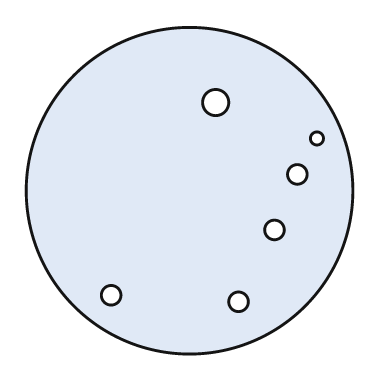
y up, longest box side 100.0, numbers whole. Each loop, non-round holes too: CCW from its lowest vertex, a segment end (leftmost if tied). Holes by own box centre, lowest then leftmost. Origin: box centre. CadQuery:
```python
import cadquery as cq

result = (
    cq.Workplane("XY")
    .moveTo(0.0, 0.0)
    .circle(50.0)
    .moveTo(15.0, -34.0)
    .circle(3.0)
    .moveTo(-24.0, -32.0)
    .circle(3.0)
    .moveTo(26.0, -12.0)
    .circle(3.0)
    .moveTo(33.0, 5.0)
    .circle(3.0)
    .moveTo(39.0, 16.0)
    .circle(2.0)
    .moveTo(8.0, 27.0)
    .circle(4.0)
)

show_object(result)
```